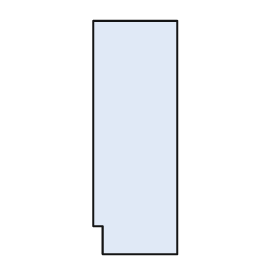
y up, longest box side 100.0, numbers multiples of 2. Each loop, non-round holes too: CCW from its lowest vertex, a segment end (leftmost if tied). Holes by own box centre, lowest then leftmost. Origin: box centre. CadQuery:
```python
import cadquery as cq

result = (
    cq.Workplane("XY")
    .moveTo(-14.0, -50.0)
    .lineTo(18.0, -50.0)
    .lineTo(18.0, 50.0)
    .lineTo(-18.0, 50.0)
    .lineTo(-18.0, -38.0)
    .lineTo(-14.0, -38.0)
    .close()
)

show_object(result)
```